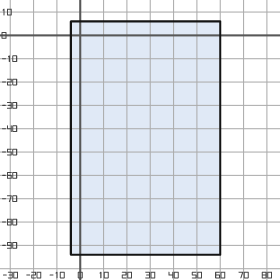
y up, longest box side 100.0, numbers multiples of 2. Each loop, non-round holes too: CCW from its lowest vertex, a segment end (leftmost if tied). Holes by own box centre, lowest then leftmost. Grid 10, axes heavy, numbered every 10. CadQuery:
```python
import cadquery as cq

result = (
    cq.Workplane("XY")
    .moveTo(-4.0, -94.0)
    .lineTo(60.0, -94.0)
    .lineTo(60.0, 6.0)
    .lineTo(-4.0, 6.0)
    .close()
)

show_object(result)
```